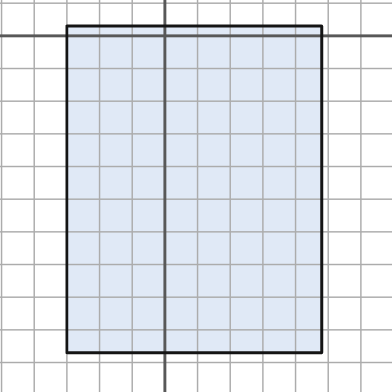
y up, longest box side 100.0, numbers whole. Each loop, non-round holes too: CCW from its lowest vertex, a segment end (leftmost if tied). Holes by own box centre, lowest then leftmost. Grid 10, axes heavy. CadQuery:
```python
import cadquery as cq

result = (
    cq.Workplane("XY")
    .moveTo(-30.0, -97.0)
    .lineTo(48.0, -97.0)
    .lineTo(48.0, 3.0)
    .lineTo(-30.0, 3.0)
    .close()
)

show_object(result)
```